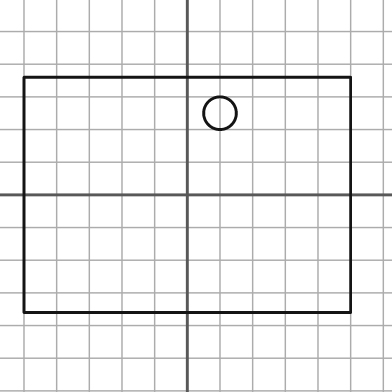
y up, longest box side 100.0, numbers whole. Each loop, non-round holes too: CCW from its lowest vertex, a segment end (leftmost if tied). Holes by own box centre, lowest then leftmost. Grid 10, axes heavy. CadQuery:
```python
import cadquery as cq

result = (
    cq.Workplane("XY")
    .moveTo(-50.0, -36.0)
    .lineTo(50.0, -36.0)
    .lineTo(50.0, 36.0)
    .lineTo(-50.0, 36.0)
    .close()
    .moveTo(10.0, 25.0)
    .circle(5.0)
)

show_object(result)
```